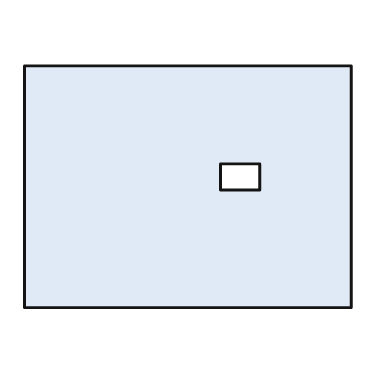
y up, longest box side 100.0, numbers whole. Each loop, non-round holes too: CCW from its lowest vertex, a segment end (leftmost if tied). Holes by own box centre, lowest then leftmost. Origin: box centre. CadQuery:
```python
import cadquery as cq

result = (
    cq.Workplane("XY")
    .moveTo(-50.0, -37.0)
    .lineTo(50.0, -37.0)
    .lineTo(50.0, 37.0)
    .lineTo(-50.0, 37.0)
    .close()
    .moveTo(10.0, -1.0)
    .lineTo(22.0, -1.0)
    .lineTo(22.0, 7.0)
    .lineTo(10.0, 7.0)
    .close()
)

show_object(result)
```